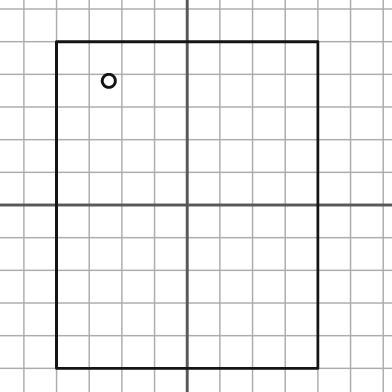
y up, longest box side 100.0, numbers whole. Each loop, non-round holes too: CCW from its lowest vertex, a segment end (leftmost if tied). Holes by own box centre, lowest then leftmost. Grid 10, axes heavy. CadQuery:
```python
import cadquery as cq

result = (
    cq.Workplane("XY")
    .moveTo(-40.0, -50.0)
    .lineTo(40.0, -50.0)
    .lineTo(40.0, 50.0)
    .lineTo(-40.0, 50.0)
    .close()
    .moveTo(-24.0, 38.0)
    .circle(2.0)
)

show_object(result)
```